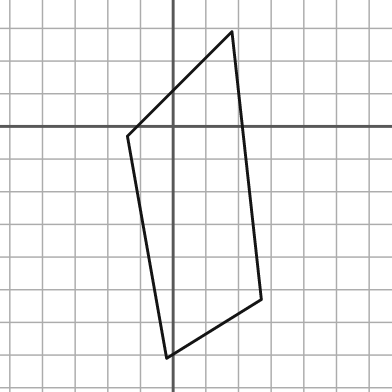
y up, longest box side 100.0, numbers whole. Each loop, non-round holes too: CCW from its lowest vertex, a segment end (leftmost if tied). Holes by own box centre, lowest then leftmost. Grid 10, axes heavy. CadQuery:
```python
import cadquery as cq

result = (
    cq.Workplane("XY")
    .moveTo(-2.0, -71.0)
    .lineTo(27.0, -53.0)
    .lineTo(18.0, 29.0)
    .lineTo(-14.0, -3.0)
    .close()
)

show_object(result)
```